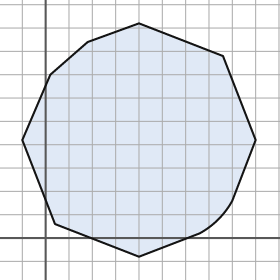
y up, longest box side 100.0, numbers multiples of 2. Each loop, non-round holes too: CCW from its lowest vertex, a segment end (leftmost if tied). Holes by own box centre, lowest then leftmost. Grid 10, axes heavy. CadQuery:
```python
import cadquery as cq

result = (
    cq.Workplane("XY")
    .moveTo(40.0, -8.0)
    .lineTo(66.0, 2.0)
    .threePointArc((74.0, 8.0), (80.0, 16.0))
    .lineTo(90.0, 42.0)
    .lineTo(76.0, 78.0)
    .lineTo(40.0, 92.0)
    .lineTo(18.0, 84.0)
    .lineTo(2.0, 70.0)
    .lineTo(-10.0, 42.0)
    .lineTo(4.0, 6.0)
    .close()
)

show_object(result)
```